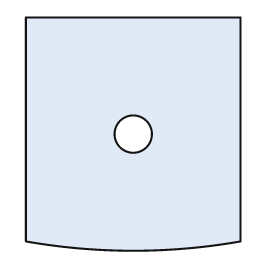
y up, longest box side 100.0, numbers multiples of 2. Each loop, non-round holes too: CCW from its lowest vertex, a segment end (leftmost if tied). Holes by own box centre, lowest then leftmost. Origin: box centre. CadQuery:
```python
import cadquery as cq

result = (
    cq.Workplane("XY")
    .moveTo(-46.0, -46.0)
    .threePointArc((0.0, -50.0), (46.0, -46.0))
    .lineTo(46.0, 50.0)
    .lineTo(-46.0, 50.0)
    .close()
    .moveTo(0.0, 0.0)
    .circle(8.0)
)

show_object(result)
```